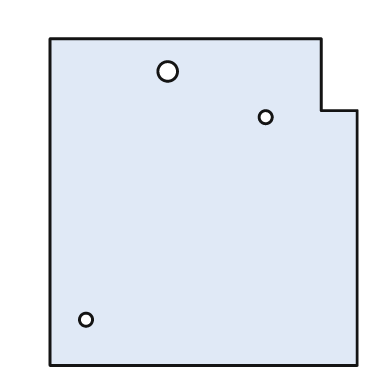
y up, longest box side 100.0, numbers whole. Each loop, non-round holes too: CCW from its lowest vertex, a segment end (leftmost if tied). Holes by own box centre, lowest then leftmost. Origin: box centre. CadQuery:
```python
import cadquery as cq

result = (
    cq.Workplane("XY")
    .moveTo(-47.0, -50.0)
    .lineTo(47.0, -50.0)
    .lineTo(47.0, 28.0)
    .lineTo(36.0, 28.0)
    .lineTo(36.0, 50.0)
    .lineTo(-47.0, 50.0)
    .close()
    .moveTo(-36.0, -36.0)
    .circle(2.0)
    .moveTo(19.0, 26.0)
    .circle(2.0)
    .moveTo(-11.0, 40.0)
    .circle(3.0)
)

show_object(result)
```